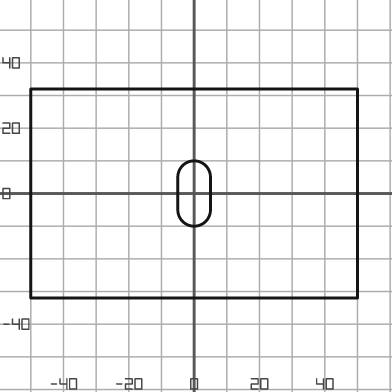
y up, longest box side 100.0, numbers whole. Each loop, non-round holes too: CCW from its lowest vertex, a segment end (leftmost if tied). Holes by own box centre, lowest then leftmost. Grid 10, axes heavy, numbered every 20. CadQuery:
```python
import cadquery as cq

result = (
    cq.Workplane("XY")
    .moveTo(-50.0, -32.0)
    .lineTo(50.0, -32.0)
    .lineTo(50.0, 32.0)
    .lineTo(-50.0, 32.0)
    .close()
    .moveTo(-5.0, -5.0)
    .threePointArc((0.0, -10.0), (5.0, -5.0))
    .lineTo(5.0, 5.0)
    .threePointArc((0.0, 10.0), (-5.0, 5.0))
    .close()
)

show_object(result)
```